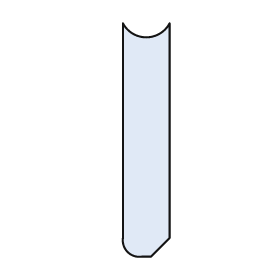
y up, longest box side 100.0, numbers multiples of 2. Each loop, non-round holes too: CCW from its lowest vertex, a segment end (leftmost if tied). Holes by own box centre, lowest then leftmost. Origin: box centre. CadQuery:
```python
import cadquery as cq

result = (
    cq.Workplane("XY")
    .moveTo(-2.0, -50.0)
    .lineTo(2.0, -50.0)
    .lineTo(10.0, -42.0)
    .lineTo(10.0, 50.0)
    .threePointArc((0.0, 44.0), (-10.0, 50.0))
    .lineTo(-10.0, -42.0)
    .threePointArc((-8.0, -48.0), (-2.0, -50.0))
    .close()
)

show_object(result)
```